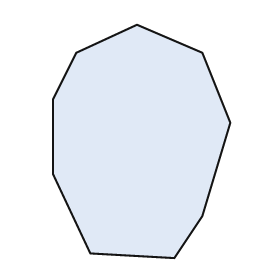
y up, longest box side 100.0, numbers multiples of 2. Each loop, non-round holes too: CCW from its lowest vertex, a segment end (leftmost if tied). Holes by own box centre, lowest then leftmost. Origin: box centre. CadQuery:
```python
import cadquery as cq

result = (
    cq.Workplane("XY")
    .moveTo(14.0, -50.0)
    .lineTo(26.0, -32.0)
    .lineTo(38.0, 8.0)
    .lineTo(26.0, 38.0)
    .lineTo(-2.0, 50.0)
    .lineTo(-28.0, 38.0)
    .lineTo(-38.0, 18.0)
    .lineTo(-38.0, -14.0)
    .lineTo(-22.0, -48.0)
    .close()
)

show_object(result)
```